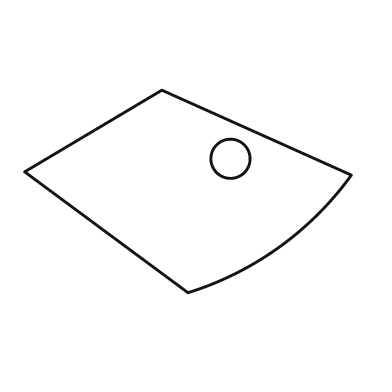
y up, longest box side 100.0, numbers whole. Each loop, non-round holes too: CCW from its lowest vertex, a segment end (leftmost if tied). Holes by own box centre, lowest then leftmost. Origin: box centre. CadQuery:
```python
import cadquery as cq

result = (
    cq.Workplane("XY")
    .moveTo(0.0, -31.0)
    .threePointArc((28.0, -17.0), (50.0, 5.0))
    .lineTo(-8.0, 31.0)
    .lineTo(-50.0, 6.0)
    .close()
    .moveTo(13.0, 10.0)
    .circle(6.0)
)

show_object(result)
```